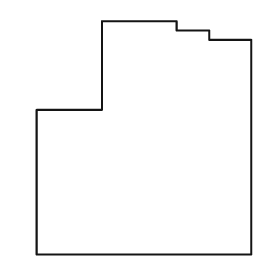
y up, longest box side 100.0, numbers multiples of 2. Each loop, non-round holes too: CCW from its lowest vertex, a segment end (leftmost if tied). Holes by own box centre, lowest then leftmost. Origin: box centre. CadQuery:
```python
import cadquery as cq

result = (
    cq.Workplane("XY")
    .moveTo(-46.0, -50.0)
    .lineTo(46.0, -50.0)
    .lineTo(46.0, 42.0)
    .lineTo(28.0, 42.0)
    .lineTo(28.0, 46.0)
    .lineTo(14.0, 46.0)
    .lineTo(14.0, 50.0)
    .lineTo(-18.0, 50.0)
    .lineTo(-18.0, 12.0)
    .lineTo(-46.0, 12.0)
    .close()
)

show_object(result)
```